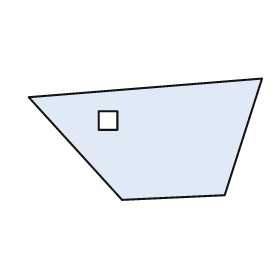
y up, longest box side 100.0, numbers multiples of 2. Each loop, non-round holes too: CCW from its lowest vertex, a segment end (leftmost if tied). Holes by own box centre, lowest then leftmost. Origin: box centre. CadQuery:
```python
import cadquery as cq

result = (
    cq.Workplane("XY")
    .moveTo(-10.0, -26.0)
    .lineTo(34.0, -24.0)
    .lineTo(50.0, 26.0)
    .lineTo(-50.0, 18.0)
    .close()
    .moveTo(-20.0, 4.0)
    .lineTo(-12.0, 4.0)
    .lineTo(-12.0, 12.0)
    .lineTo(-20.0, 12.0)
    .close()
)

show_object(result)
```